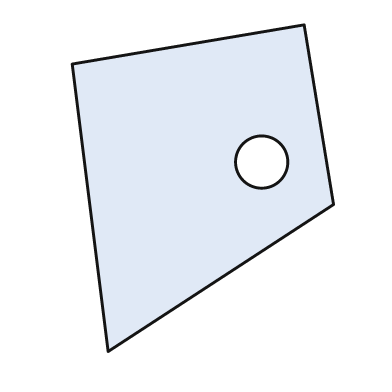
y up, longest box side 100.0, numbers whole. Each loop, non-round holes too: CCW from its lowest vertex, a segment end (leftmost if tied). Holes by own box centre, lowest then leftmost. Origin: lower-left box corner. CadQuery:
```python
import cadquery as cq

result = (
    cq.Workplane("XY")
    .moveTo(11.0, 0.0)
    .lineTo(80.0, 45.0)
    .lineTo(71.0, 100.0)
    .lineTo(0.0, 88.0)
    .close()
    .moveTo(58.0, 58.0)
    .circle(8.0)
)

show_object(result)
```